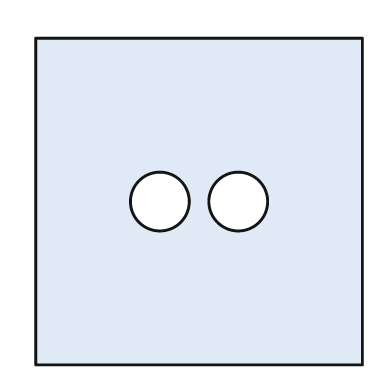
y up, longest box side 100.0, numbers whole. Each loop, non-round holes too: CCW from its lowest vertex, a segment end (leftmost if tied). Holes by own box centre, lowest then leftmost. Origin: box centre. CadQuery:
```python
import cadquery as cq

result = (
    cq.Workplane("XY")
    .moveTo(-50.0, -50.0)
    .lineTo(50.0, -50.0)
    .lineTo(50.0, 50.0)
    .lineTo(-50.0, 50.0)
    .close()
    .moveTo(-12.0, 0.0)
    .circle(9.0)
    .moveTo(12.0, 0.0)
    .circle(9.0)
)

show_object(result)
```